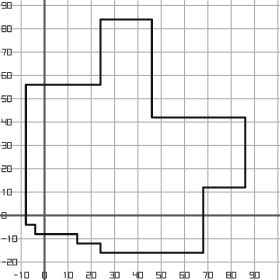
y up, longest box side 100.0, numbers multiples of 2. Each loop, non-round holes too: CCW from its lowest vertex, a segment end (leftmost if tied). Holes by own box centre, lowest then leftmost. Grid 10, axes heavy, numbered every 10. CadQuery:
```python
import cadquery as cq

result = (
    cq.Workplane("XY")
    .moveTo(24.0, -16.0)
    .lineTo(68.0, -16.0)
    .lineTo(68.0, 12.0)
    .lineTo(86.0, 12.0)
    .lineTo(86.0, 42.0)
    .lineTo(46.0, 42.0)
    .lineTo(46.0, 84.0)
    .lineTo(24.0, 84.0)
    .lineTo(24.0, 56.0)
    .lineTo(-8.0, 56.0)
    .lineTo(-8.0, -4.0)
    .lineTo(-4.0, -4.0)
    .lineTo(-4.0, -8.0)
    .lineTo(14.0, -8.0)
    .lineTo(14.0, -12.0)
    .lineTo(24.0, -12.0)
    .close()
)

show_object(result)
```